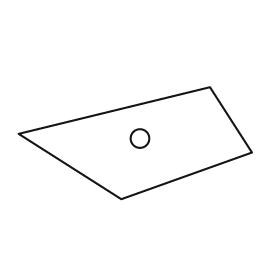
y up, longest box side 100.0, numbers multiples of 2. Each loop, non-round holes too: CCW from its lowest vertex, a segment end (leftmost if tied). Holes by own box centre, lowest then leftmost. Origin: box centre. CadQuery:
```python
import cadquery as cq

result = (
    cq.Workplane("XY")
    .moveTo(-6.0, -24.0)
    .lineTo(50.0, -4.0)
    .lineTo(32.0, 24.0)
    .lineTo(-50.0, 4.0)
    .close()
    .moveTo(2.0, 2.0)
    .circle(4.0)
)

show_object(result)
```